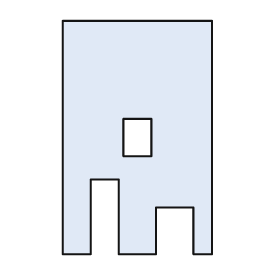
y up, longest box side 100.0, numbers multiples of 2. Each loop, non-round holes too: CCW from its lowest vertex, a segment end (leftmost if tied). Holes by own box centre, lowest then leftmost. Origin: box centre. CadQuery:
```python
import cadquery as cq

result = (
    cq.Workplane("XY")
    .moveTo(-32.0, -50.0)
    .lineTo(-20.0, -50.0)
    .lineTo(-20.0, -18.0)
    .lineTo(-8.0, -18.0)
    .lineTo(-8.0, -50.0)
    .lineTo(8.0, -50.0)
    .lineTo(8.0, -30.0)
    .lineTo(24.0, -30.0)
    .lineTo(24.0, -50.0)
    .lineTo(32.0, -50.0)
    .lineTo(32.0, 50.0)
    .lineTo(-32.0, 50.0)
    .close()
    .moveTo(-6.0, -8.0)
    .lineTo(6.0, -8.0)
    .lineTo(6.0, 8.0)
    .lineTo(-6.0, 8.0)
    .close()
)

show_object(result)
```